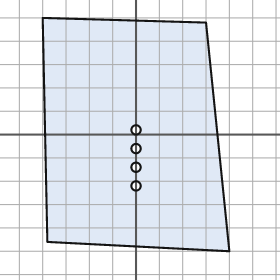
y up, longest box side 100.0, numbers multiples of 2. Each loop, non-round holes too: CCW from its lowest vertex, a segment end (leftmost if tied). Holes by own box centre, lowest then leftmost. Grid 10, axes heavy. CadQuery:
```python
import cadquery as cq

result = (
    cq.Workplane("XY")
    .moveTo(40.0, -50.0)
    .lineTo(30.0, 48.0)
    .lineTo(-40.0, 50.0)
    .lineTo(-38.0, -46.0)
    .close()
    .moveTo(0.0, -22.0)
    .circle(2.0)
    .moveTo(0.0, -14.0)
    .circle(2.0)
    .moveTo(0.0, -6.0)
    .circle(2.0)
    .moveTo(0.0, 2.0)
    .circle(2.0)
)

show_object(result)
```